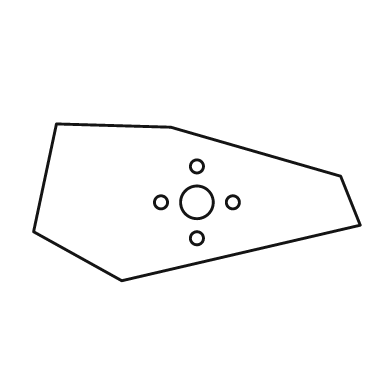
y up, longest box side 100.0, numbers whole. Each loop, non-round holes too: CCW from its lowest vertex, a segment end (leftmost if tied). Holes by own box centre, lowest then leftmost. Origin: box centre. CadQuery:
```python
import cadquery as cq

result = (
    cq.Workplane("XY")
    .moveTo(-23.0, -24.0)
    .lineTo(50.0, -7.0)
    .lineTo(44.0, 8.0)
    .lineTo(-8.0, 23.0)
    .lineTo(-43.0, 24.0)
    .lineTo(-50.0, -9.0)
    .close()
    .moveTo(0.0, -11.0)
    .circle(2.0)
    .moveTo(-11.0, 0.0)
    .circle(2.0)
    .moveTo(0.0, 0.0)
    .circle(5.0)
    .moveTo(11.0, 0.0)
    .circle(2.0)
    .moveTo(0.0, 11.0)
    .circle(2.0)
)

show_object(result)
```